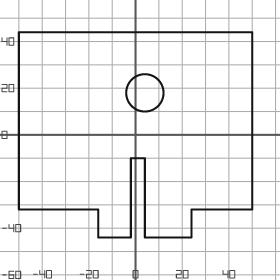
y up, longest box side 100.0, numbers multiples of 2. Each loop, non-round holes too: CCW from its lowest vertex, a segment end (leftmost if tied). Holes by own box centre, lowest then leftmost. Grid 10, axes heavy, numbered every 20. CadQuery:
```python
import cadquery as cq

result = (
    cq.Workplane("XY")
    .moveTo(-16.0, -44.0)
    .lineTo(-2.0, -44.0)
    .lineTo(-2.0, -10.0)
    .lineTo(4.0, -10.0)
    .lineTo(4.0, -44.0)
    .lineTo(24.0, -44.0)
    .lineTo(24.0, -32.0)
    .lineTo(50.0, -32.0)
    .lineTo(50.0, 44.0)
    .lineTo(-50.0, 44.0)
    .lineTo(-50.0, -32.0)
    .lineTo(-16.0, -32.0)
    .close()
    .moveTo(4.0, 18.0)
    .circle(8.0)
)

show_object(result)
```